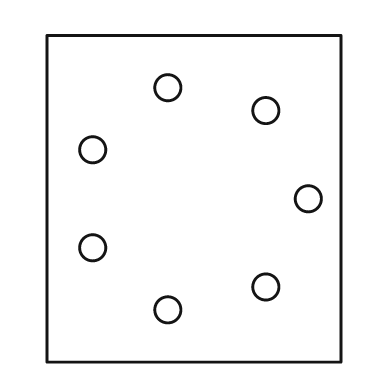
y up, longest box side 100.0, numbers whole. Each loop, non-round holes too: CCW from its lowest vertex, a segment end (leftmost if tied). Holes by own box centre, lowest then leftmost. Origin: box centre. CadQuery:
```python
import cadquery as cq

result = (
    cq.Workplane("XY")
    .moveTo(-45.0, -50.0)
    .lineTo(45.0, -50.0)
    .lineTo(45.0, 50.0)
    .lineTo(-45.0, 50.0)
    .close()
    .moveTo(-8.0, -34.0)
    .circle(4.0)
    .moveTo(22.0, -27.0)
    .circle(4.0)
    .moveTo(-31.0, -15.0)
    .circle(4.0)
    .moveTo(35.0, 0.0)
    .circle(4.0)
    .moveTo(-31.0, 15.0)
    .circle(4.0)
    .moveTo(22.0, 27.0)
    .circle(4.0)
    .moveTo(-8.0, 34.0)
    .circle(4.0)
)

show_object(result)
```